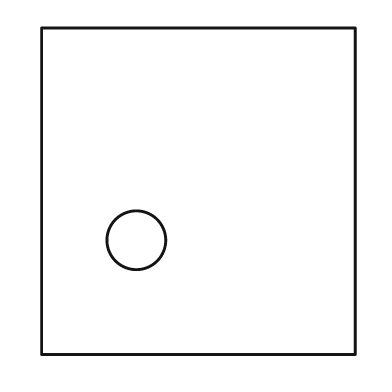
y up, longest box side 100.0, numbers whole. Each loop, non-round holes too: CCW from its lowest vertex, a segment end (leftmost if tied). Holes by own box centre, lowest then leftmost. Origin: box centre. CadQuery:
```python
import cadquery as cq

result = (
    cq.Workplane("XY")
    .moveTo(-48.0, -50.0)
    .lineTo(48.0, -50.0)
    .lineTo(48.0, 50.0)
    .lineTo(-48.0, 50.0)
    .close()
    .moveTo(-19.0, -15.0)
    .circle(9.0)
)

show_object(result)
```